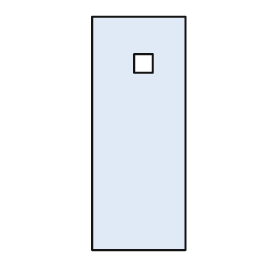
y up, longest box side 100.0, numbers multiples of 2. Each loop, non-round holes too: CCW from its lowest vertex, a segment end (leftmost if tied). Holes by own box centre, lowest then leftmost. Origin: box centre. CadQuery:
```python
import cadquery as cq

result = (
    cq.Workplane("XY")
    .moveTo(-20.0, -50.0)
    .lineTo(20.0, -50.0)
    .lineTo(20.0, 50.0)
    .lineTo(-20.0, 50.0)
    .close()
    .moveTo(-2.0, 26.0)
    .lineTo(6.0, 26.0)
    .lineTo(6.0, 34.0)
    .lineTo(-2.0, 34.0)
    .close()
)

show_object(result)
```